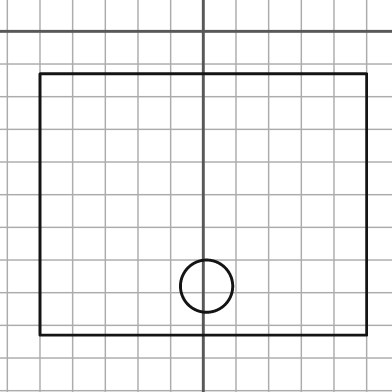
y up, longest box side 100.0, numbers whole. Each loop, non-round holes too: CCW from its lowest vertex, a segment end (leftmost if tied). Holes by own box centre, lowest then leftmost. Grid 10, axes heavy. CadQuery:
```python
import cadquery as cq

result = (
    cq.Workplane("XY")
    .moveTo(-50.0, -93.0)
    .lineTo(50.0, -93.0)
    .lineTo(50.0, -13.0)
    .lineTo(-50.0, -13.0)
    .close()
    .moveTo(1.0, -78.0)
    .circle(8.0)
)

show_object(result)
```